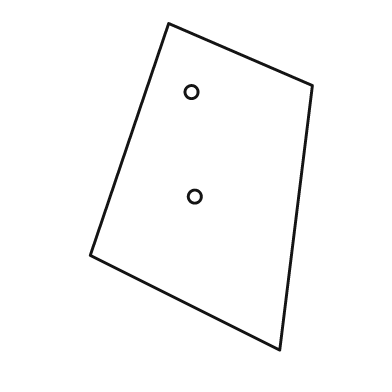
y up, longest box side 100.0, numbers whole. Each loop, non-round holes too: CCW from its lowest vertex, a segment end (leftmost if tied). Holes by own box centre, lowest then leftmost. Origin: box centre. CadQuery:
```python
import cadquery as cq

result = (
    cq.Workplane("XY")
    .moveTo(24.0, -50.0)
    .lineTo(34.0, 31.0)
    .lineTo(-10.0, 50.0)
    .lineTo(-34.0, -21.0)
    .close()
    .moveTo(-2.0, -3.0)
    .circle(2.0)
    .moveTo(-3.0, 29.0)
    .circle(2.0)
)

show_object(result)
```